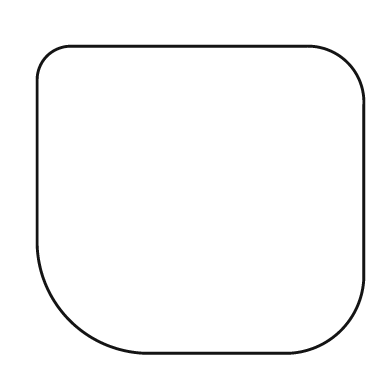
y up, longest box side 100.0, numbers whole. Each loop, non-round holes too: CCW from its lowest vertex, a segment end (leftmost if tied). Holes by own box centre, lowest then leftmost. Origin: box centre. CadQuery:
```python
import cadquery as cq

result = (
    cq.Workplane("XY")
    .moveTo(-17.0, -47.0)
    .lineTo(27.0, -47.0)
    .threePointArc((43.0, -40.0), (50.0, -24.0))
    .lineTo(50.0, 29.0)
    .threePointArc((45.0, 42.0), (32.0, 47.0))
    .lineTo(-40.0, 47.0)
    .threePointArc((-47.0, 44.0), (-50.0, 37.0))
    .lineTo(-50.0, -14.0)
    .threePointArc((-40.0, -37.0), (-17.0, -47.0))
    .close()
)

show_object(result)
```